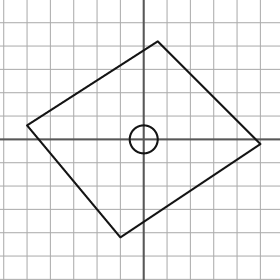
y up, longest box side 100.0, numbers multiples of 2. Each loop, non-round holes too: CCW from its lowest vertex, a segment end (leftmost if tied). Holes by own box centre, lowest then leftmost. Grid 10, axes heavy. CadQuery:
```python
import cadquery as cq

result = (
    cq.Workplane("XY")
    .moveTo(-10.0, -42.0)
    .lineTo(50.0, -2.0)
    .lineTo(6.0, 42.0)
    .lineTo(-50.0, 6.0)
    .close()
    .moveTo(0.0, 0.0)
    .circle(6.0)
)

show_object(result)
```